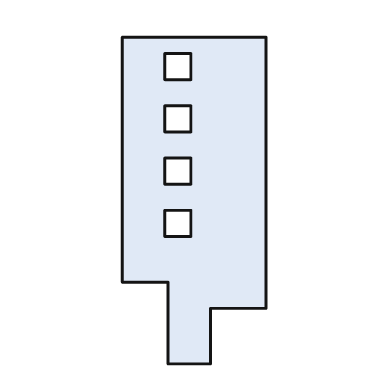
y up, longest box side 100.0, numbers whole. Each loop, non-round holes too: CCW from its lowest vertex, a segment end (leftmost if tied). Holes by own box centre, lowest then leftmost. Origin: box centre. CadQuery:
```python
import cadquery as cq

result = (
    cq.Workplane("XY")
    .moveTo(-8.0, -50.0)
    .lineTo(5.0, -50.0)
    .lineTo(5.0, -33.0)
    .lineTo(22.0, -33.0)
    .lineTo(22.0, 50.0)
    .lineTo(-22.0, 50.0)
    .lineTo(-22.0, -25.0)
    .lineTo(-8.0, -25.0)
    .close()
    .moveTo(-9.0, -11.0)
    .lineTo(-1.0, -11.0)
    .lineTo(-1.0, -3.0)
    .lineTo(-9.0, -3.0)
    .close()
    .moveTo(-9.0, 5.0)
    .lineTo(-1.0, 5.0)
    .lineTo(-1.0, 13.0)
    .lineTo(-9.0, 13.0)
    .close()
    .moveTo(-9.0, 21.0)
    .lineTo(-1.0, 21.0)
    .lineTo(-1.0, 29.0)
    .lineTo(-9.0, 29.0)
    .close()
    .moveTo(-9.0, 37.0)
    .lineTo(-1.0, 37.0)
    .lineTo(-1.0, 45.0)
    .lineTo(-9.0, 45.0)
    .close()
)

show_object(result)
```